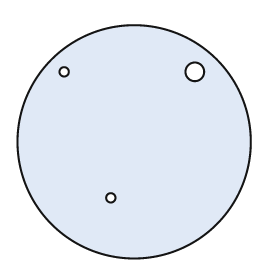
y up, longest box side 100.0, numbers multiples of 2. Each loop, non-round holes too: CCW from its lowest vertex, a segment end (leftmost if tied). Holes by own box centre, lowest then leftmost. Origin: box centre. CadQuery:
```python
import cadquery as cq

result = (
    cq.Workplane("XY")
    .moveTo(0.0, 0.0)
    .circle(50.0)
    .moveTo(-10.0, -24.0)
    .circle(2.0)
    .moveTo(-30.0, 30.0)
    .circle(2.0)
    .moveTo(26.0, 30.0)
    .circle(4.0)
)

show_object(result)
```